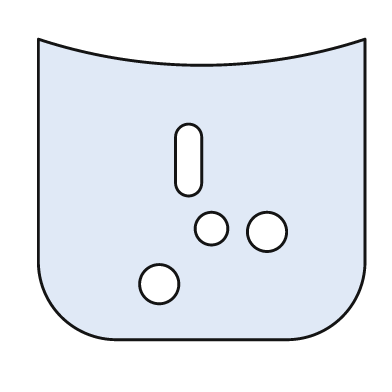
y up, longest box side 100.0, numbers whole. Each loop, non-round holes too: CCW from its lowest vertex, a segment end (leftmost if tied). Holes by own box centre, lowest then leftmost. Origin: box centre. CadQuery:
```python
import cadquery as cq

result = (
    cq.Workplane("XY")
    .moveTo(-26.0, -46.0)
    .lineTo(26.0, -46.0)
    .threePointArc((43.0, -39.0), (50.0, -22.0))
    .lineTo(50.0, 46.0)
    .threePointArc((0.0, 38.0), (-50.0, 46.0))
    .lineTo(-50.0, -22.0)
    .threePointArc((-43.0, -39.0), (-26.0, -46.0))
    .close()
    .moveTo(-13.0, -29.0)
    .circle(6.0)
    .moveTo(20.0, -13.0)
    .circle(6.0)
    .moveTo(3.0, -12.0)
    .circle(5.0)
    .moveTo(-8.0, 2.0)
    .threePointArc((-4.0, -2.0), (0.0, 2.0))
    .lineTo(0.0, 16.0)
    .threePointArc((-4.0, 20.0), (-8.0, 16.0))
    .close()
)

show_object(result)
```